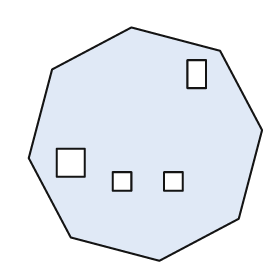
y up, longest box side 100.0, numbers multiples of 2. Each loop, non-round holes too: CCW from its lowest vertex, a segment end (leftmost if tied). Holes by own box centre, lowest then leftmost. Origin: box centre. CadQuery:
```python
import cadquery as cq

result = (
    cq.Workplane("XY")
    .moveTo(6.0, -50.0)
    .lineTo(40.0, -32.0)
    .lineTo(50.0, 6.0)
    .lineTo(32.0, 40.0)
    .lineTo(-6.0, 50.0)
    .lineTo(-40.0, 32.0)
    .lineTo(-50.0, -6.0)
    .lineTo(-32.0, -40.0)
    .close()
    .moveTo(-14.0, -20.0)
    .lineTo(-6.0, -20.0)
    .lineTo(-6.0, -12.0)
    .lineTo(-14.0, -12.0)
    .close()
    .moveTo(8.0, -20.0)
    .lineTo(16.0, -20.0)
    .lineTo(16.0, -12.0)
    .lineTo(8.0, -12.0)
    .close()
    .moveTo(-38.0, -14.0)
    .lineTo(-26.0, -14.0)
    .lineTo(-26.0, -2.0)
    .lineTo(-38.0, -2.0)
    .close()
    .moveTo(18.0, 24.0)
    .lineTo(26.0, 24.0)
    .lineTo(26.0, 36.0)
    .lineTo(18.0, 36.0)
    .close()
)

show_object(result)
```